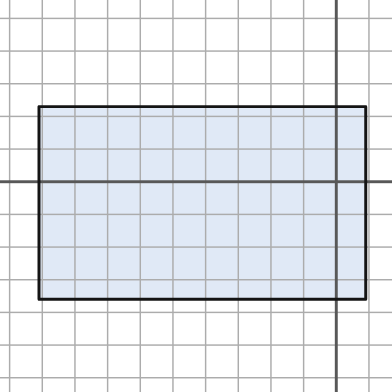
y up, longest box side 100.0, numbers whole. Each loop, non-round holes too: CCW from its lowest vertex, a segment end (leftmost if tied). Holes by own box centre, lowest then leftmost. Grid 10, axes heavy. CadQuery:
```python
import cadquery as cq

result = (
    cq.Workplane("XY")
    .moveTo(-91.0, -36.0)
    .lineTo(9.0, -36.0)
    .lineTo(9.0, 23.0)
    .lineTo(-91.0, 23.0)
    .close()
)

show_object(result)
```